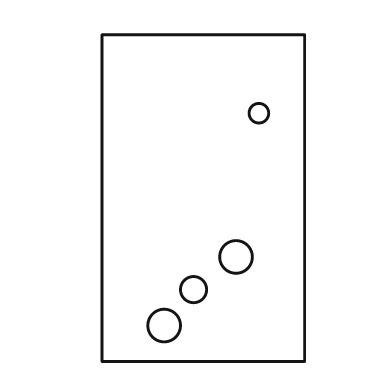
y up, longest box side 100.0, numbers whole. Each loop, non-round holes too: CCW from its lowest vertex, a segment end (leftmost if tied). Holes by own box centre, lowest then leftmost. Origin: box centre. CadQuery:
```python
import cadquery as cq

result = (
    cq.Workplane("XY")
    .moveTo(-31.0, -50.0)
    .lineTo(31.0, -50.0)
    .lineTo(31.0, 50.0)
    .lineTo(-31.0, 50.0)
    .close()
    .moveTo(-12.0, -39.0)
    .circle(5.0)
    .moveTo(-3.0, -28.0)
    .circle(4.0)
    .moveTo(10.0, -18.0)
    .circle(5.0)
    .moveTo(17.0, 26.0)
    .circle(3.0)
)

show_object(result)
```